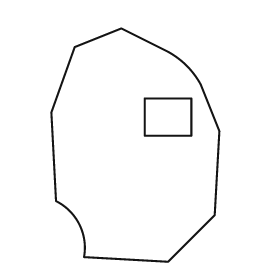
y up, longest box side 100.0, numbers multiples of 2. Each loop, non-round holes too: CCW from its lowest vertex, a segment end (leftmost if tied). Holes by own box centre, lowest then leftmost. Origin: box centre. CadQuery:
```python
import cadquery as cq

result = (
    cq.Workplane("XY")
    .moveTo(14.0, -50.0)
    .lineTo(34.0, -30.0)
    .lineTo(36.0, 6.0)
    .lineTo(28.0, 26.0)
    .threePointArc((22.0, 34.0), (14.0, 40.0))
    .lineTo(-6.0, 50.0)
    .lineTo(-26.0, 42.0)
    .lineTo(-36.0, 14.0)
    .lineTo(-34.0, -24.0)
    .threePointArc((-24.0, -34.0), (-22.0, -48.0))
    .close()
    .moveTo(4.0, 4.0)
    .lineTo(24.0, 4.0)
    .lineTo(24.0, 20.0)
    .lineTo(4.0, 20.0)
    .close()
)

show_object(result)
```